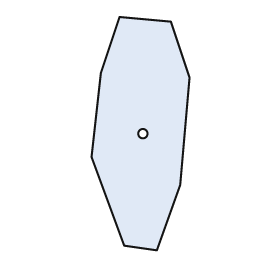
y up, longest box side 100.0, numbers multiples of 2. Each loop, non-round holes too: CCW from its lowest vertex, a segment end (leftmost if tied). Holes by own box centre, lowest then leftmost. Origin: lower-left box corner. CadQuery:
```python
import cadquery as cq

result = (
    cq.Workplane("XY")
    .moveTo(28.0, 0.0)
    .lineTo(38.0, 28.0)
    .lineTo(42.0, 74.0)
    .lineTo(34.0, 98.0)
    .lineTo(12.0, 100.0)
    .lineTo(4.0, 76.0)
    .lineTo(0.0, 40.0)
    .lineTo(14.0, 2.0)
    .close()
    .moveTo(22.0, 50.0)
    .circle(2.0)
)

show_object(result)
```